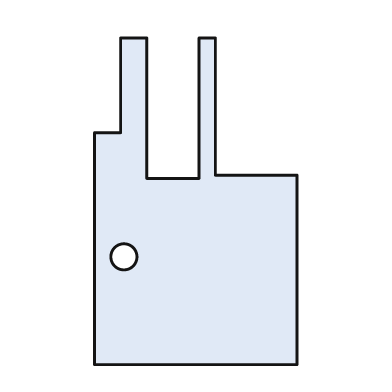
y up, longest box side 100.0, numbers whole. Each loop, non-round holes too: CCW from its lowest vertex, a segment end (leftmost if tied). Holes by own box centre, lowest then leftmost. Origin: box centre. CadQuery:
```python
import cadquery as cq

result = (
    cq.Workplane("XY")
    .moveTo(-31.0, -50.0)
    .lineTo(31.0, -50.0)
    .lineTo(31.0, 8.0)
    .lineTo(6.0, 8.0)
    .lineTo(6.0, 50.0)
    .lineTo(1.0, 50.0)
    .lineTo(1.0, 7.0)
    .lineTo(-15.0, 7.0)
    .lineTo(-15.0, 50.0)
    .lineTo(-23.0, 50.0)
    .lineTo(-23.0, 21.0)
    .lineTo(-31.0, 21.0)
    .close()
    .moveTo(-22.0, -17.0)
    .circle(4.0)
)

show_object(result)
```